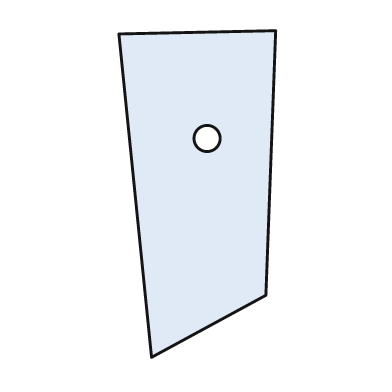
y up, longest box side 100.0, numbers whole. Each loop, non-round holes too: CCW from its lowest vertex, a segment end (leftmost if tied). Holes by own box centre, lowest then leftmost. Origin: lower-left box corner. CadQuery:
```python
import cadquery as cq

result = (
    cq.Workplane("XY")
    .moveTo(10.0, 0.0)
    .lineTo(45.0, 19.0)
    .lineTo(48.0, 100.0)
    .lineTo(0.0, 99.0)
    .close()
    .moveTo(27.0, 67.0)
    .circle(4.0)
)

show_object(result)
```